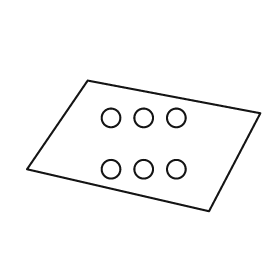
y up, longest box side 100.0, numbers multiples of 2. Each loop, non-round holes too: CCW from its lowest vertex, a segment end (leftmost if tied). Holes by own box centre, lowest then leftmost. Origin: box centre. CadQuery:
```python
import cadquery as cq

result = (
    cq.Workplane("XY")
    .moveTo(28.0, -28.0)
    .lineTo(50.0, 14.0)
    .lineTo(-24.0, 28.0)
    .lineTo(-50.0, -10.0)
    .close()
    .moveTo(-14.0, -10.0)
    .circle(4.0)
    .moveTo(0.0, -10.0)
    .circle(4.0)
    .moveTo(14.0, -10.0)
    .circle(4.0)
    .moveTo(-14.0, 12.0)
    .circle(4.0)
    .moveTo(0.0, 12.0)
    .circle(4.0)
    .moveTo(14.0, 12.0)
    .circle(4.0)
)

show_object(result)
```